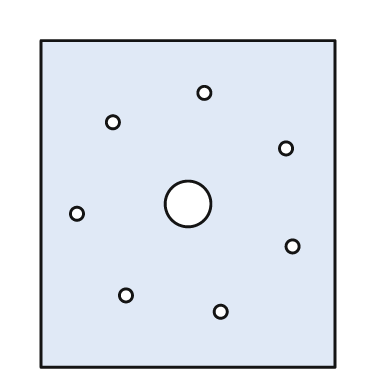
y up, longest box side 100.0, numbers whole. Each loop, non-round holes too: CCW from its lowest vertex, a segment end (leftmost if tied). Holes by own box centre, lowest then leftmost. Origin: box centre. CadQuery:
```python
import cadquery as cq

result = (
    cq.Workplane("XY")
    .moveTo(-45.0, -50.0)
    .lineTo(45.0, -50.0)
    .lineTo(45.0, 50.0)
    .lineTo(-45.0, 50.0)
    .close()
    .moveTo(10.0, -33.0)
    .circle(2.0)
    .moveTo(-19.0, -28.0)
    .circle(2.0)
    .moveTo(32.0, -13.0)
    .circle(2.0)
    .moveTo(-34.0, -3.0)
    .circle(2.0)
    .moveTo(0.0, 0.0)
    .circle(7.0)
    .moveTo(30.0, 17.0)
    .circle(2.0)
    .moveTo(-23.0, 25.0)
    .circle(2.0)
    .moveTo(5.0, 34.0)
    .circle(2.0)
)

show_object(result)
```